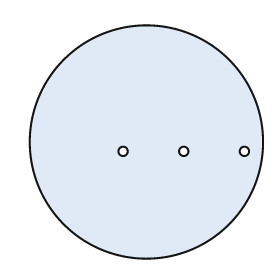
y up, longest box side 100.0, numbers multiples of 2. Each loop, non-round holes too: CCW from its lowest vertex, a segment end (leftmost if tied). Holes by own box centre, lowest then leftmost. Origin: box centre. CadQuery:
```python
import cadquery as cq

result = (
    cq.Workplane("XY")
    .moveTo(0.0, 0.0)
    .circle(50.0)
    .moveTo(-10.0, -4.0)
    .circle(2.0)
    .moveTo(16.0, -4.0)
    .circle(2.0)
    .moveTo(42.0, -4.0)
    .circle(2.0)
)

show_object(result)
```